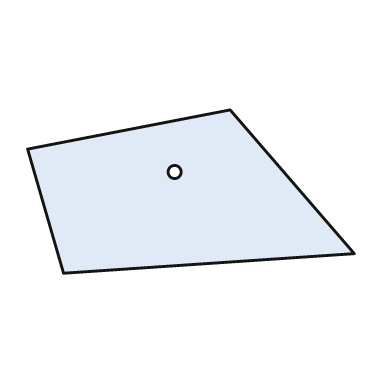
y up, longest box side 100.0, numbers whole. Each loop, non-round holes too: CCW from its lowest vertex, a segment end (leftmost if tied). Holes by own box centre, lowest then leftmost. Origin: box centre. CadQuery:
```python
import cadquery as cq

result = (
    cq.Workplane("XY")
    .moveTo(-39.0, -25.0)
    .lineTo(50.0, -19.0)
    .lineTo(12.0, 25.0)
    .lineTo(-50.0, 13.0)
    .close()
    .moveTo(-5.0, 6.0)
    .circle(2.0)
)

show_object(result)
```